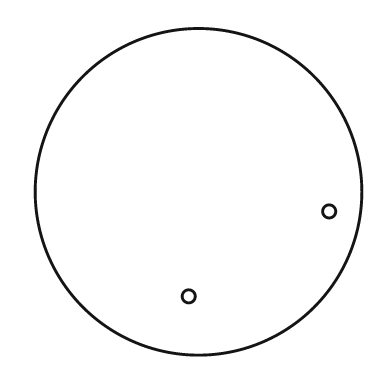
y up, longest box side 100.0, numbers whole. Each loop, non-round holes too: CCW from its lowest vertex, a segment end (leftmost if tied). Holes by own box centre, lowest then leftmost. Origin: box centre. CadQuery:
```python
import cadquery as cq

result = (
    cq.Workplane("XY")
    .moveTo(0.0, 0.0)
    .circle(50.0)
    .moveTo(-3.0, -32.0)
    .circle(2.0)
    .moveTo(40.0, -6.0)
    .circle(2.0)
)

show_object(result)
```